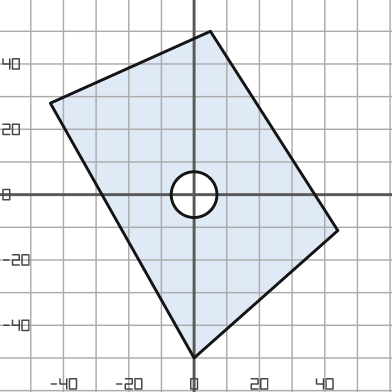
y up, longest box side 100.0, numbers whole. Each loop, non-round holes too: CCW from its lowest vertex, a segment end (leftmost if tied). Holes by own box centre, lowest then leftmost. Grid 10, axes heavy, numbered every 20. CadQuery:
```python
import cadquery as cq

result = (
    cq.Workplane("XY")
    .moveTo(0.0, -50.0)
    .lineTo(44.0, -11.0)
    .lineTo(5.0, 50.0)
    .lineTo(-44.0, 28.0)
    .close()
    .moveTo(0.0, 0.0)
    .circle(7.0)
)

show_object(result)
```